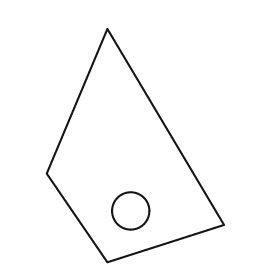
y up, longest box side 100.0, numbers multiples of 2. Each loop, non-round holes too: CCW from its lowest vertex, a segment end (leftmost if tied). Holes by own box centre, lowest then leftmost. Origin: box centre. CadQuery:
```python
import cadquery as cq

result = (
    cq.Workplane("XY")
    .moveTo(-12.0, -50.0)
    .lineTo(38.0, -34.0)
    .lineTo(-12.0, 50.0)
    .lineTo(-38.0, -12.0)
    .close()
    .moveTo(-2.0, -28.0)
    .circle(8.0)
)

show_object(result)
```